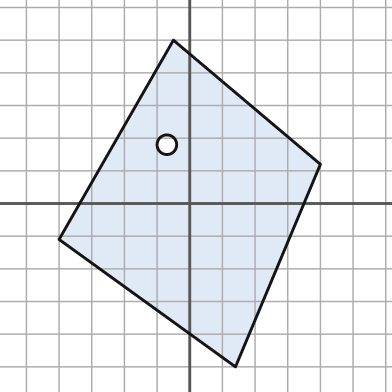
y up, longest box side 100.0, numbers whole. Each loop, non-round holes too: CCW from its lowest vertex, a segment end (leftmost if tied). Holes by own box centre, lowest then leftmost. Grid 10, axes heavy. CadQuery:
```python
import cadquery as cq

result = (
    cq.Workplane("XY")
    .moveTo(14.0, -50.0)
    .lineTo(40.0, 12.0)
    .lineTo(-5.0, 50.0)
    .lineTo(-40.0, -11.0)
    .close()
    .moveTo(-7.0, 18.0)
    .circle(3.0)
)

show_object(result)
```